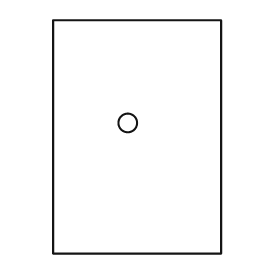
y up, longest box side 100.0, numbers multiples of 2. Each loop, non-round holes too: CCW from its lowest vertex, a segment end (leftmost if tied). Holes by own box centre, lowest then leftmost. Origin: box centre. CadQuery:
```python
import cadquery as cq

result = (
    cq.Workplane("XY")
    .moveTo(-36.0, -50.0)
    .lineTo(36.0, -50.0)
    .lineTo(36.0, 50.0)
    .lineTo(-36.0, 50.0)
    .close()
    .moveTo(-4.0, 6.0)
    .circle(4.0)
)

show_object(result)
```